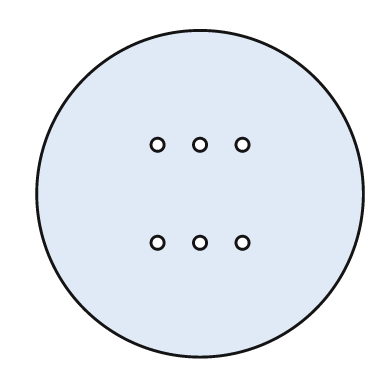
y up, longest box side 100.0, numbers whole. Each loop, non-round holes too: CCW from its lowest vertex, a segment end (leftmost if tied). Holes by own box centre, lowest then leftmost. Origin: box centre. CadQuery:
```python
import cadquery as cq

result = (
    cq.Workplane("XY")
    .moveTo(0.0, 0.0)
    .circle(50.0)
    .moveTo(-13.0, -15.0)
    .circle(2.0)
    .moveTo(0.0, -15.0)
    .circle(2.0)
    .moveTo(13.0, -15.0)
    .circle(2.0)
    .moveTo(-13.0, 15.0)
    .circle(2.0)
    .moveTo(0.0, 15.0)
    .circle(2.0)
    .moveTo(13.0, 15.0)
    .circle(2.0)
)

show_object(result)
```